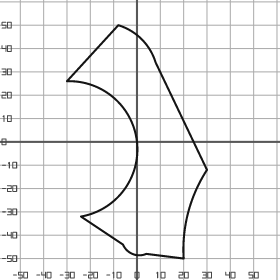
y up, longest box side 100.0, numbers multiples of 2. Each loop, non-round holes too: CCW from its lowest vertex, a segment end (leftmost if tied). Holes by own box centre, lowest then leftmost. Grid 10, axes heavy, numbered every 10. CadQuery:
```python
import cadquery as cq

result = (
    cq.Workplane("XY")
    .moveTo(20.0, -50.0)
    .threePointArc((22.0, -30.0), (30.0, -12.0))
    .lineTo(8.0, 34.0)
    .threePointArc((2.0, 44.0), (-8.0, 50.0))
    .lineTo(-30.0, 26.0)
    .threePointArc((0.0, 0.0), (-24.0, -32.0))
    .lineTo(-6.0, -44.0)
    .threePointArc((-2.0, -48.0), (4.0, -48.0))
    .close()
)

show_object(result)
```